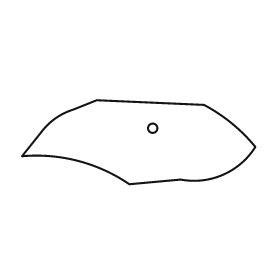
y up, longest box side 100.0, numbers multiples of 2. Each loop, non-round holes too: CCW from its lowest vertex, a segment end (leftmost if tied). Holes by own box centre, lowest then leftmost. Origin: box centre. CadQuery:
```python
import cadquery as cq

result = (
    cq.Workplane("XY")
    .moveTo(-4.0, -18.0)
    .lineTo(18.0, -16.0)
    .threePointArc((36.0, -14.0), (50.0, -2.0))
    .threePointArc((40.0, 8.0), (28.0, 16.0))
    .lineTo(-18.0, 18.0)
    .lineTo(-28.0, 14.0)
    .threePointArc((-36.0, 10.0), (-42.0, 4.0))
    .lineTo(-50.0, -6.0)
    .threePointArc((-26.0, -8.0), (-4.0, -18.0))
    .close()
    .moveTo(6.0, 6.0)
    .circle(2.0)
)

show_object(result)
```